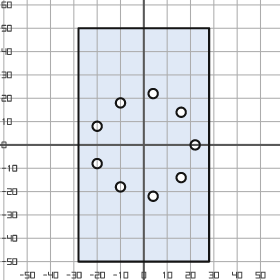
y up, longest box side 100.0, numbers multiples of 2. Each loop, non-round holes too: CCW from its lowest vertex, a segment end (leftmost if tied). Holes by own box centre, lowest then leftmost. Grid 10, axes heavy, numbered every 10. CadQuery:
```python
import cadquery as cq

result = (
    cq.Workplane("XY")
    .moveTo(-28.0, -50.0)
    .lineTo(28.0, -50.0)
    .lineTo(28.0, 50.0)
    .lineTo(-28.0, 50.0)
    .close()
    .moveTo(4.0, -22.0)
    .circle(2.0)
    .moveTo(-10.0, -18.0)
    .circle(2.0)
    .moveTo(16.0, -14.0)
    .circle(2.0)
    .moveTo(-20.0, -8.0)
    .circle(2.0)
    .moveTo(22.0, 0.0)
    .circle(2.0)
    .moveTo(-20.0, 8.0)
    .circle(2.0)
    .moveTo(16.0, 14.0)
    .circle(2.0)
    .moveTo(-10.0, 18.0)
    .circle(2.0)
    .moveTo(4.0, 22.0)
    .circle(2.0)
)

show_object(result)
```